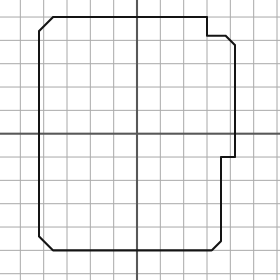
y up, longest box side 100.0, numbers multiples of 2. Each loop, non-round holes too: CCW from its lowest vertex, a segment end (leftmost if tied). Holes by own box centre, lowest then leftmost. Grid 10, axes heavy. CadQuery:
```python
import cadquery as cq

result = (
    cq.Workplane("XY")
    .moveTo(-36.0, -50.0)
    .lineTo(32.0, -50.0)
    .lineTo(36.0, -46.0)
    .lineTo(36.0, -10.0)
    .lineTo(42.0, -10.0)
    .lineTo(42.0, 38.0)
    .lineTo(38.0, 42.0)
    .lineTo(30.0, 42.0)
    .lineTo(30.0, 50.0)
    .lineTo(-36.0, 50.0)
    .lineTo(-42.0, 44.0)
    .lineTo(-42.0, -44.0)
    .close()
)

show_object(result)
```